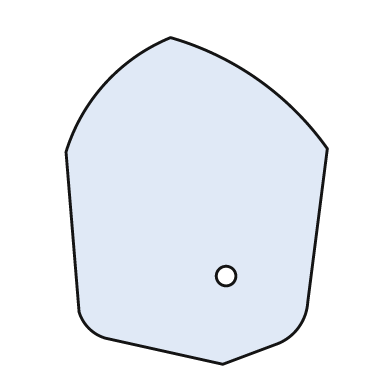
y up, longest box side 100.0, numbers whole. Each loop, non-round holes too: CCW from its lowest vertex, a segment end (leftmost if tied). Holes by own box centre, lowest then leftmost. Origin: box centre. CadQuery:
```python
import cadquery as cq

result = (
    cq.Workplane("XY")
    .moveTo(8.0, -50.0)
    .lineTo(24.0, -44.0)
    .threePointArc((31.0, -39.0), (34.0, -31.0))
    .lineTo(40.0, 16.0)
    .threePointArc((19.0, 37.0), (-8.0, 50.0))
    .threePointArc((-28.0, 36.0), (-40.0, 15.0))
    .lineTo(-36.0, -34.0)
    .threePointArc((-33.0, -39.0), (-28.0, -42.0))
    .close()
    .moveTo(9.0, -23.0)
    .circle(3.0)
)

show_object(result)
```